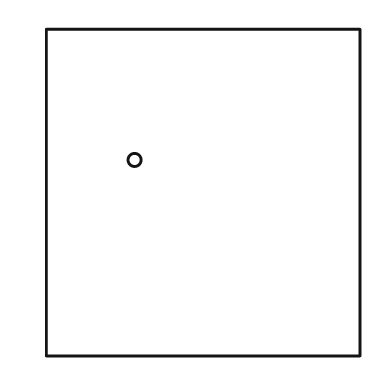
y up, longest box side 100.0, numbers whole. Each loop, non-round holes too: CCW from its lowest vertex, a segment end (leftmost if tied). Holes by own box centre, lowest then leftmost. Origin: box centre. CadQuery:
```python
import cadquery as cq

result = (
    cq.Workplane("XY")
    .moveTo(-48.0, -50.0)
    .lineTo(48.0, -50.0)
    .lineTo(48.0, 50.0)
    .lineTo(-48.0, 50.0)
    .close()
    .moveTo(-21.0, 10.0)
    .circle(2.0)
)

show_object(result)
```